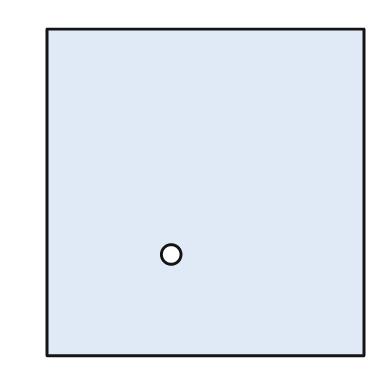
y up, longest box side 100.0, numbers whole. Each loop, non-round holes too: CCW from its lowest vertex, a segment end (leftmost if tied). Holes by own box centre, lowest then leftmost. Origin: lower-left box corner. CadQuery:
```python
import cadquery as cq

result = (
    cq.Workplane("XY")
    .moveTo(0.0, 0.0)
    .lineTo(97.0, 0.0)
    .lineTo(97.0, 100.0)
    .lineTo(0.0, 100.0)
    .close()
    .moveTo(38.0, 31.0)
    .circle(3.0)
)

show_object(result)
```